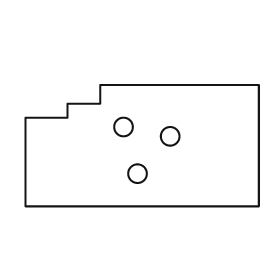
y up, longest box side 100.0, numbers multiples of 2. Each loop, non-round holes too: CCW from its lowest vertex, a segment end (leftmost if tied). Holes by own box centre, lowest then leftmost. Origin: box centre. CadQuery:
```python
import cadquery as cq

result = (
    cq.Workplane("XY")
    .moveTo(-50.0, -26.0)
    .lineTo(50.0, -26.0)
    .lineTo(50.0, 26.0)
    .lineTo(-18.0, 26.0)
    .lineTo(-18.0, 18.0)
    .lineTo(-32.0, 18.0)
    .lineTo(-32.0, 12.0)
    .lineTo(-50.0, 12.0)
    .close()
    .moveTo(-2.0, -12.0)
    .circle(4.0)
    .moveTo(12.0, 4.0)
    .circle(4.0)
    .moveTo(-8.0, 8.0)
    .circle(4.0)
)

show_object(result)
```